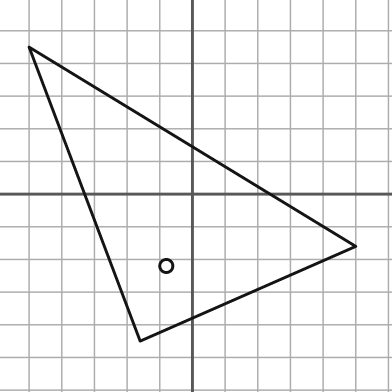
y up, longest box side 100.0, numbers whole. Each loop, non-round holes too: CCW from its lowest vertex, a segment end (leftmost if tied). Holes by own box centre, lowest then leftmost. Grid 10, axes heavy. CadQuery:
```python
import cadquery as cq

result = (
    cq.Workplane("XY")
    .moveTo(-16.0, -45.0)
    .lineTo(50.0, -16.0)
    .lineTo(-50.0, 45.0)
    .close()
    .moveTo(-8.0, -22.0)
    .circle(2.0)
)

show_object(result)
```